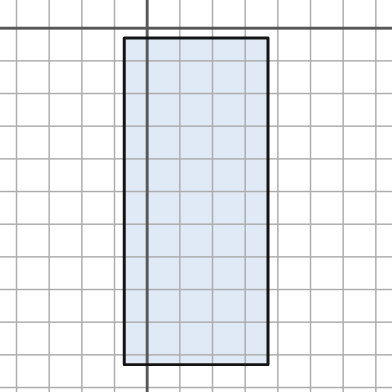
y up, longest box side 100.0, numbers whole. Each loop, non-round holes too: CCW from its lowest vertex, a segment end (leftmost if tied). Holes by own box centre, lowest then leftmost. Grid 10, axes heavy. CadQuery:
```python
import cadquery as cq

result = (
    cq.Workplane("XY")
    .moveTo(-7.0, -103.0)
    .lineTo(37.0, -103.0)
    .lineTo(37.0, -3.0)
    .lineTo(-7.0, -3.0)
    .close()
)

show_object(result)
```